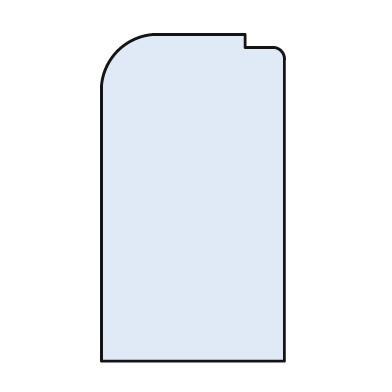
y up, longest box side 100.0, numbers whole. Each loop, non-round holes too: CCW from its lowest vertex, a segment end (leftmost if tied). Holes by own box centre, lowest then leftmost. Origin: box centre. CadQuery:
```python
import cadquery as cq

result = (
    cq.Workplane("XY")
    .moveTo(-28.0, -50.0)
    .lineTo(28.0, -50.0)
    .lineTo(28.0, 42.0)
    .threePointArc((27.0, 45.0), (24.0, 46.0))
    .lineTo(16.0, 46.0)
    .lineTo(16.0, 50.0)
    .lineTo(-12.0, 50.0)
    .threePointArc((-23.0, 45.0), (-28.0, 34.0))
    .close()
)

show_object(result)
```